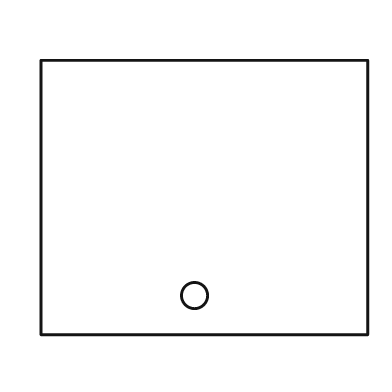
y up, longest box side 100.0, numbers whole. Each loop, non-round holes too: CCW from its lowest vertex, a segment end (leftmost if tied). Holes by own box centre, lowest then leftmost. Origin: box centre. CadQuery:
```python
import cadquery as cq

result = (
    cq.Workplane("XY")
    .moveTo(-50.0, -42.0)
    .lineTo(50.0, -42.0)
    .lineTo(50.0, 42.0)
    .lineTo(-50.0, 42.0)
    .close()
    .moveTo(-3.0, -30.0)
    .circle(4.0)
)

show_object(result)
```